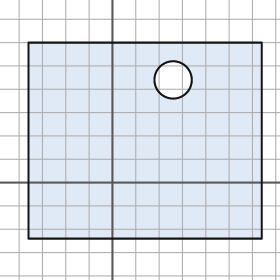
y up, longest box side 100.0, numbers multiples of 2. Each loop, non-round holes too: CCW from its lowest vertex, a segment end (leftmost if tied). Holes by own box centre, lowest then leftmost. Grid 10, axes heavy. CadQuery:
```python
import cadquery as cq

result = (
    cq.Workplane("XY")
    .moveTo(-36.0, -24.0)
    .lineTo(64.0, -24.0)
    .lineTo(64.0, 60.0)
    .lineTo(-36.0, 60.0)
    .close()
    .moveTo(26.0, 44.0)
    .circle(8.0)
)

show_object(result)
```